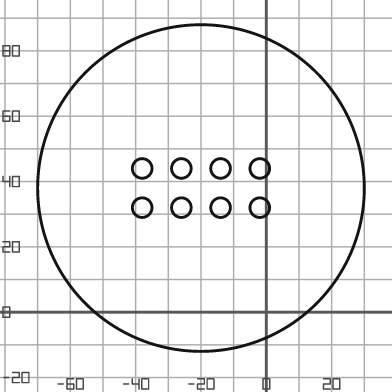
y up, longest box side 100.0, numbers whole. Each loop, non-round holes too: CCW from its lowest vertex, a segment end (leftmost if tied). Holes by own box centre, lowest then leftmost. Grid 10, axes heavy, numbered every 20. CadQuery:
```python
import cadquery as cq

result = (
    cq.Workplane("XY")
    .moveTo(-20.0, 38.0)
    .circle(50.0)
    .moveTo(-38.0, 32.0)
    .circle(3.0)
    .moveTo(-26.0, 32.0)
    .circle(3.0)
    .moveTo(-14.0, 32.0)
    .circle(3.0)
    .moveTo(-2.0, 32.0)
    .circle(3.0)
    .moveTo(-38.0, 44.0)
    .circle(3.0)
    .moveTo(-26.0, 44.0)
    .circle(3.0)
    .moveTo(-14.0, 44.0)
    .circle(3.0)
    .moveTo(-2.0, 44.0)
    .circle(3.0)
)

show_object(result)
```